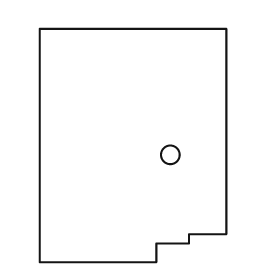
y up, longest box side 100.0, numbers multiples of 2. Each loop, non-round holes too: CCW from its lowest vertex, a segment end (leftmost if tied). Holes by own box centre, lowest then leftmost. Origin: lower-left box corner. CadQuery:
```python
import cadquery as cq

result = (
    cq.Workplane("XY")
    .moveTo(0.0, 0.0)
    .lineTo(50.0, 0.0)
    .lineTo(50.0, 8.0)
    .lineTo(64.0, 8.0)
    .lineTo(64.0, 12.0)
    .lineTo(80.0, 12.0)
    .lineTo(80.0, 100.0)
    .lineTo(0.0, 100.0)
    .close()
    .moveTo(56.0, 46.0)
    .circle(4.0)
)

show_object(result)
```